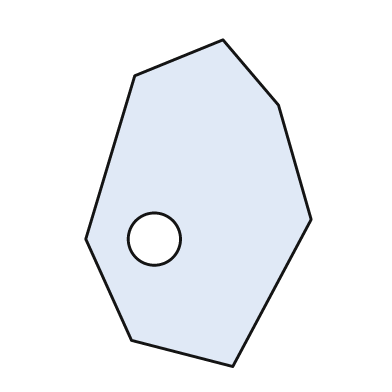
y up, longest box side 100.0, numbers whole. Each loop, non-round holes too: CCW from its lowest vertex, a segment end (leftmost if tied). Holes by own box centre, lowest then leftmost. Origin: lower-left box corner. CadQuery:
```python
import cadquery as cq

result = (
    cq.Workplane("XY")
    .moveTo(45.0, 0.0)
    .lineTo(69.0, 45.0)
    .lineTo(59.0, 80.0)
    .lineTo(42.0, 100.0)
    .lineTo(15.0, 89.0)
    .lineTo(0.0, 39.0)
    .lineTo(14.0, 8.0)
    .close()
    .moveTo(21.0, 39.0)
    .circle(8.0)
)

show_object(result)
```